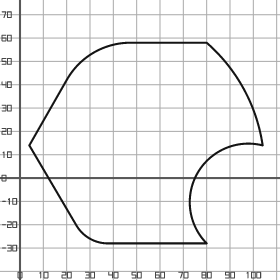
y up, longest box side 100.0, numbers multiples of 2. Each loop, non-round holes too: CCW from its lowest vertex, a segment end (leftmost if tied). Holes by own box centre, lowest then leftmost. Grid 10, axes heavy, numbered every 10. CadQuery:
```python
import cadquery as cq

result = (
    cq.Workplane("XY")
    .moveTo(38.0, -28.0)
    .lineTo(80.0, -28.0)
    .threePointArc((76.0, 2.0), (104.0, 14.0))
    .threePointArc((96.0, 38.0), (80.0, 58.0))
    .lineTo(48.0, 58.0)
    .threePointArc((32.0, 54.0), (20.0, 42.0))
    .lineTo(4.0, 14.0)
    .lineTo(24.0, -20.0)
    .threePointArc((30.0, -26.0), (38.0, -28.0))
    .close()
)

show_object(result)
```